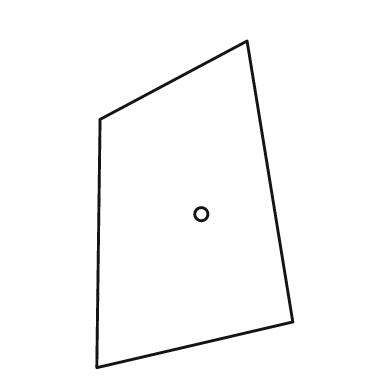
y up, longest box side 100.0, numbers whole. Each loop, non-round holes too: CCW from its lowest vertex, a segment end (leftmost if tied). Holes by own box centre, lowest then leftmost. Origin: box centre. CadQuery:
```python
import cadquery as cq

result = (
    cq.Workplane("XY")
    .moveTo(-30.0, -50.0)
    .lineTo(30.0, -36.0)
    .lineTo(16.0, 50.0)
    .lineTo(-29.0, 26.0)
    .close()
    .moveTo(2.0, -3.0)
    .circle(2.0)
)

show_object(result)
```